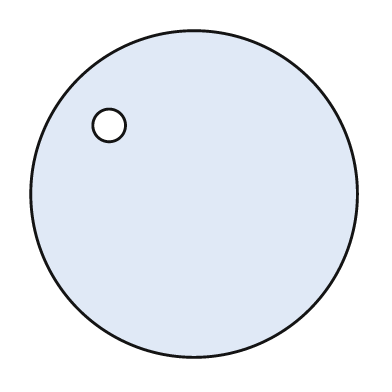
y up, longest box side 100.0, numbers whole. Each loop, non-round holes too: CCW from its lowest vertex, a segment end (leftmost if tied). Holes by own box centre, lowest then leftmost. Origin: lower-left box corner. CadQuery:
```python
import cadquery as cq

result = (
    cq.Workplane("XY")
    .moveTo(50.0, 50.0)
    .circle(50.0)
    .moveTo(24.0, 71.0)
    .circle(5.0)
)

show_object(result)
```